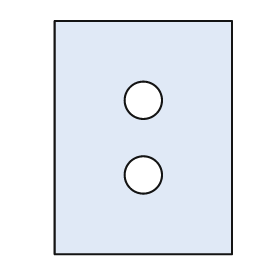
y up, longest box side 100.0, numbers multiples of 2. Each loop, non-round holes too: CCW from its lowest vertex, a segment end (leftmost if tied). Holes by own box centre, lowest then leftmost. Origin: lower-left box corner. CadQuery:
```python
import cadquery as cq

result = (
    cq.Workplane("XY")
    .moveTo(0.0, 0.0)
    .lineTo(76.0, 0.0)
    .lineTo(76.0, 100.0)
    .lineTo(0.0, 100.0)
    .close()
    .moveTo(38.0, 34.0)
    .circle(8.0)
    .moveTo(38.0, 66.0)
    .circle(8.0)
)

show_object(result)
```